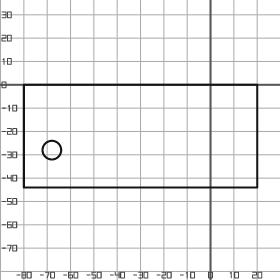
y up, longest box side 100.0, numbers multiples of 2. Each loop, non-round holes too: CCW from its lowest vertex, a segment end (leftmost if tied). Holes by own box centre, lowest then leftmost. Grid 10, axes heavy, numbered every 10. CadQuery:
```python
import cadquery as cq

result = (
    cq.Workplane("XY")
    .moveTo(-80.0, -44.0)
    .lineTo(20.0, -44.0)
    .lineTo(20.0, 0.0)
    .lineTo(-80.0, 0.0)
    .close()
    .moveTo(-68.0, -28.0)
    .circle(4.0)
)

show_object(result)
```